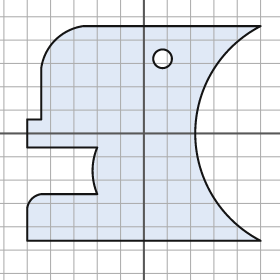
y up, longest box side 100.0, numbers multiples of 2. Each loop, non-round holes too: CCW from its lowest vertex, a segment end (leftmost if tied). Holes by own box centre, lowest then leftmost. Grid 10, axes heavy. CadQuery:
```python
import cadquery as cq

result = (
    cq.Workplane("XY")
    .moveTo(-50.0, -46.0)
    .lineTo(50.0, -46.0)
    .threePointArc((22.0, 0.0), (50.0, 46.0))
    .lineTo(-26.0, 46.0)
    .threePointArc((-38.0, 40.0), (-44.0, 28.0))
    .lineTo(-44.0, 6.0)
    .lineTo(-50.0, 6.0)
    .lineTo(-50.0, -6.0)
    .lineTo(-20.0, -6.0)
    .threePointArc((-22.0, -16.0), (-20.0, -26.0))
    .lineTo(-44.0, -26.0)
    .threePointArc((-48.0, -28.0), (-50.0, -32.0))
    .close()
    .moveTo(8.0, 32.0)
    .circle(4.0)
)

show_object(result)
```